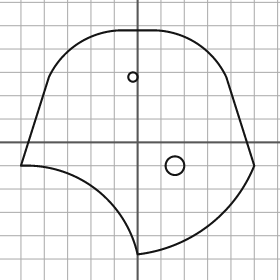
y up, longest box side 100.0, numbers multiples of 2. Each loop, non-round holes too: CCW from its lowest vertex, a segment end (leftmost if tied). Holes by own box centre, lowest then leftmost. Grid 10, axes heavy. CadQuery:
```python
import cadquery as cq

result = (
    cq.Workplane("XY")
    .moveTo(0.0, -48.0)
    .threePointArc((30.0, -36.0), (50.0, -10.0))
    .lineTo(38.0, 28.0)
    .threePointArc((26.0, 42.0), (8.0, 48.0))
    .lineTo(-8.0, 48.0)
    .threePointArc((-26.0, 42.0), (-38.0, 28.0))
    .lineTo(-50.0, -10.0)
    .threePointArc((-18.0, -20.0), (0.0, -48.0))
    .close()
    .moveTo(16.0, -10.0)
    .circle(4.0)
    .moveTo(-2.0, 28.0)
    .circle(2.0)
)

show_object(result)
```